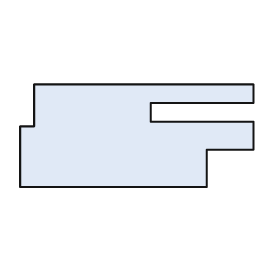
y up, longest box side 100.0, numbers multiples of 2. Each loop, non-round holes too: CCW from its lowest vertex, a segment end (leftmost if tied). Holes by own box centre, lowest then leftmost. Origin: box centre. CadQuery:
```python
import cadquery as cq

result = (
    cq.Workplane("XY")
    .moveTo(-50.0, -22.0)
    .lineTo(30.0, -22.0)
    .lineTo(30.0, -6.0)
    .lineTo(50.0, -6.0)
    .lineTo(50.0, 6.0)
    .lineTo(6.0, 6.0)
    .lineTo(6.0, 14.0)
    .lineTo(50.0, 14.0)
    .lineTo(50.0, 22.0)
    .lineTo(-44.0, 22.0)
    .lineTo(-44.0, 4.0)
    .lineTo(-50.0, 4.0)
    .close()
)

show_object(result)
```